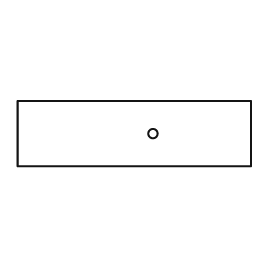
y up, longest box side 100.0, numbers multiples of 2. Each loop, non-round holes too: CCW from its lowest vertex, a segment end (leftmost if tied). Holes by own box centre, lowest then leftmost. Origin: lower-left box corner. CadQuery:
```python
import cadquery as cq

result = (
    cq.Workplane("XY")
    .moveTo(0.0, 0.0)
    .lineTo(100.0, 0.0)
    .lineTo(100.0, 28.0)
    .lineTo(0.0, 28.0)
    .close()
    .moveTo(58.0, 14.0)
    .circle(2.0)
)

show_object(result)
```